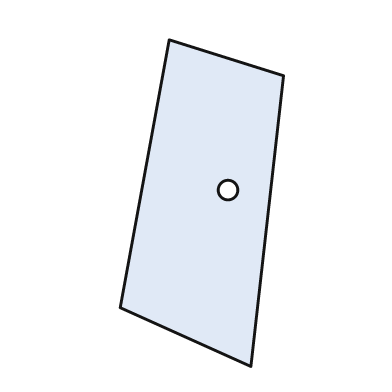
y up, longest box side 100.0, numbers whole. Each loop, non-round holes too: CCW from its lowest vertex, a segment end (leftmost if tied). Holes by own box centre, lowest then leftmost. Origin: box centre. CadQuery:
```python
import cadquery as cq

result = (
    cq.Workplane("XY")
    .moveTo(15.0, -50.0)
    .lineTo(25.0, 39.0)
    .lineTo(-10.0, 50.0)
    .lineTo(-25.0, -32.0)
    .close()
    .moveTo(8.0, 4.0)
    .circle(3.0)
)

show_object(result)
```